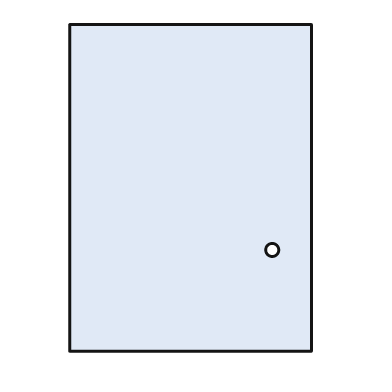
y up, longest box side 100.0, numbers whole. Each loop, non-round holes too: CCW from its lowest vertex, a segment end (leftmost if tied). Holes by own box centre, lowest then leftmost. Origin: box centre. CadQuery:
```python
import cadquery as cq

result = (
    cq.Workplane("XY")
    .moveTo(-37.0, -50.0)
    .lineTo(37.0, -50.0)
    .lineTo(37.0, 50.0)
    .lineTo(-37.0, 50.0)
    .close()
    .moveTo(25.0, -19.0)
    .circle(2.0)
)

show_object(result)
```